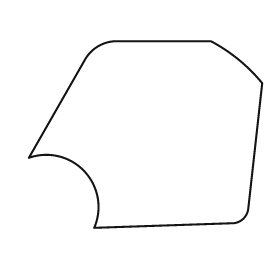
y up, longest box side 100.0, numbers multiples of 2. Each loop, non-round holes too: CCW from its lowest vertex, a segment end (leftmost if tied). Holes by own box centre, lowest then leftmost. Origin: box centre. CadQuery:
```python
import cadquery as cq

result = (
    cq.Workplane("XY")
    .moveTo(-22.0, -40.0)
    .lineTo(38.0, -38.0)
    .threePointArc((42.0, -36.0), (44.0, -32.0))
    .lineTo(50.0, 22.0)
    .threePointArc((40.0, 32.0), (28.0, 40.0))
    .lineTo(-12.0, 40.0)
    .threePointArc((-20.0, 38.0), (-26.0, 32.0))
    .lineTo(-50.0, -10.0)
    .threePointArc((-26.0, -16.0), (-22.0, -40.0))
    .close()
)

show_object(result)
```